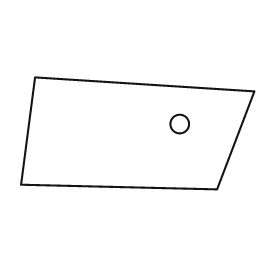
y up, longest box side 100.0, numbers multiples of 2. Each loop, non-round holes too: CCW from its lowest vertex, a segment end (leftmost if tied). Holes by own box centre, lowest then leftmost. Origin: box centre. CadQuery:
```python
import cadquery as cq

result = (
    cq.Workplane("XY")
    .moveTo(34.0, -24.0)
    .lineTo(50.0, 18.0)
    .lineTo(-44.0, 24.0)
    .lineTo(-50.0, -22.0)
    .close()
    .moveTo(18.0, 4.0)
    .circle(4.0)
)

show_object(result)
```